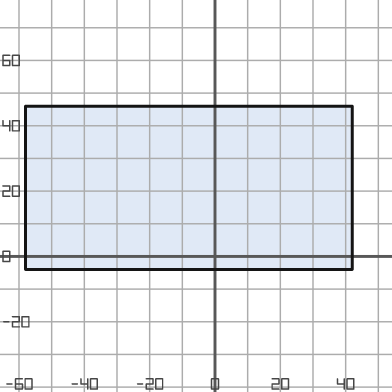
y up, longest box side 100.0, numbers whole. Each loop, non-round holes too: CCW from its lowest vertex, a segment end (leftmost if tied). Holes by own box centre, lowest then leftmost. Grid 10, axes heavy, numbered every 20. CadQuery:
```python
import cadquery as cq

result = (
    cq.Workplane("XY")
    .moveTo(-58.0, -4.0)
    .lineTo(42.0, -4.0)
    .lineTo(42.0, 46.0)
    .lineTo(-58.0, 46.0)
    .close()
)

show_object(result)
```